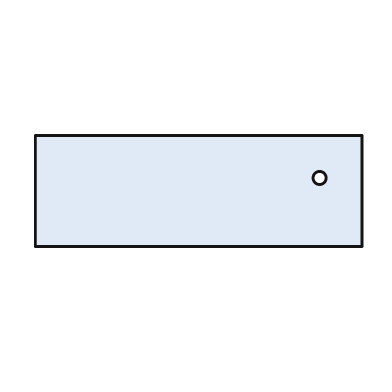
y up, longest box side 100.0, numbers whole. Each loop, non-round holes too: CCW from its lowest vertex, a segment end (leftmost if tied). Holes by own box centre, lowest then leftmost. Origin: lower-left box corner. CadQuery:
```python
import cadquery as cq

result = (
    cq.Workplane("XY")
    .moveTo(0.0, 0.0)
    .lineTo(100.0, 0.0)
    .lineTo(100.0, 34.0)
    .lineTo(0.0, 34.0)
    .close()
    .moveTo(87.0, 21.0)
    .circle(2.0)
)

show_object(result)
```